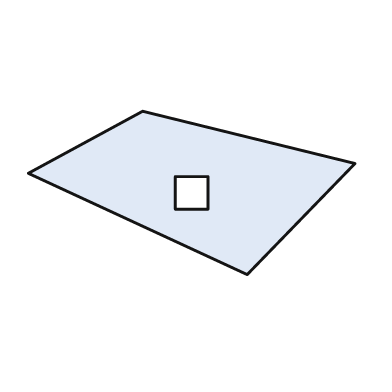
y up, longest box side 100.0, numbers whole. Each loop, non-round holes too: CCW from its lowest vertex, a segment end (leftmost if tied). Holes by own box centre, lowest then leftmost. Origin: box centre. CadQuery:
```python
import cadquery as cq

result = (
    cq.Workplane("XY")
    .moveTo(17.0, -25.0)
    .lineTo(50.0, 9.0)
    .lineTo(-15.0, 25.0)
    .lineTo(-50.0, 6.0)
    .close()
    .moveTo(-5.0, -5.0)
    .lineTo(5.0, -5.0)
    .lineTo(5.0, 5.0)
    .lineTo(-5.0, 5.0)
    .close()
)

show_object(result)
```